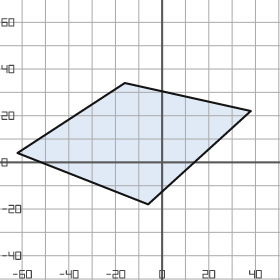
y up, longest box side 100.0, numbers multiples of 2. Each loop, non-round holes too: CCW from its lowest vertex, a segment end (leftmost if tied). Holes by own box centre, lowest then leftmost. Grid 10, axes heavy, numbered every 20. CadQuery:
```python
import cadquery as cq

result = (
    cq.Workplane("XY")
    .moveTo(-6.0, -18.0)
    .lineTo(38.0, 22.0)
    .lineTo(-16.0, 34.0)
    .lineTo(-62.0, 4.0)
    .close()
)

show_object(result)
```